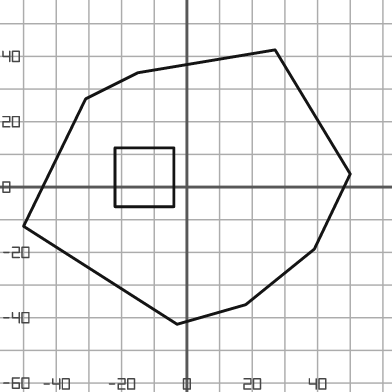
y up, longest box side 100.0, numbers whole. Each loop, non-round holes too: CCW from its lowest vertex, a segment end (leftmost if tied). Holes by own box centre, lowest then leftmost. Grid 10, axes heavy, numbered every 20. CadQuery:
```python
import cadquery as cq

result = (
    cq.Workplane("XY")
    .moveTo(-3.0, -42.0)
    .lineTo(18.0, -36.0)
    .lineTo(39.0, -19.0)
    .lineTo(50.0, 4.0)
    .lineTo(27.0, 42.0)
    .lineTo(-15.0, 35.0)
    .lineTo(-31.0, 27.0)
    .lineTo(-50.0, -12.0)
    .close()
    .moveTo(-22.0, -6.0)
    .lineTo(-4.0, -6.0)
    .lineTo(-4.0, 12.0)
    .lineTo(-22.0, 12.0)
    .close()
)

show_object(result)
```